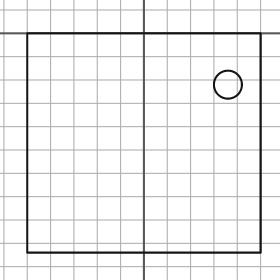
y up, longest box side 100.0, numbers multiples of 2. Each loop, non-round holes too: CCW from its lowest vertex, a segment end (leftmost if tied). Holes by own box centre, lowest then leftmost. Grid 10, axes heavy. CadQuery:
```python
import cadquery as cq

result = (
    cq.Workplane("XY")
    .moveTo(-50.0, -94.0)
    .lineTo(50.0, -94.0)
    .lineTo(50.0, 0.0)
    .lineTo(-50.0, 0.0)
    .close()
    .moveTo(36.0, -22.0)
    .circle(6.0)
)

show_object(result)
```